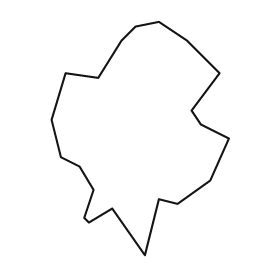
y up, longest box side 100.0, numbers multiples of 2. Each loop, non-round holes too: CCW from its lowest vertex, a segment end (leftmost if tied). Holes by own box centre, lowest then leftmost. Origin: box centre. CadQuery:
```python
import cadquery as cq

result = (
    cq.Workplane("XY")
    .moveTo(2.0, -50.0)
    .lineTo(8.0, -26.0)
    .lineTo(16.0, -28.0)
    .lineTo(30.0, -18.0)
    .lineTo(38.0, 0.0)
    .lineTo(26.0, 6.0)
    .lineTo(22.0, 12.0)
    .lineTo(34.0, 28.0)
    .lineTo(20.0, 42.0)
    .lineTo(8.0, 50.0)
    .lineTo(-2.0, 48.0)
    .lineTo(-8.0, 42.0)
    .lineTo(-18.0, 26.0)
    .lineTo(-32.0, 28.0)
    .lineTo(-38.0, 8.0)
    .lineTo(-34.0, -8.0)
    .lineTo(-26.0, -12.0)
    .lineTo(-20.0, -22.0)
    .lineTo(-24.0, -34.0)
    .lineTo(-22.0, -36.0)
    .lineTo(-12.0, -30.0)
    .close()
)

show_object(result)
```